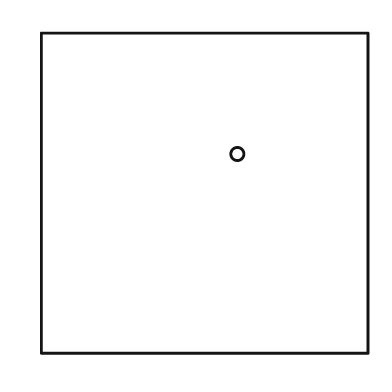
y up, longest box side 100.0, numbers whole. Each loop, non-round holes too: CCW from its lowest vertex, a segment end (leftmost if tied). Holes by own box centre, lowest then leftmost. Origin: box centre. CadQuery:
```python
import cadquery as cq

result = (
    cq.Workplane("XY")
    .moveTo(-50.0, -49.0)
    .lineTo(50.0, -49.0)
    .lineTo(50.0, 49.0)
    .lineTo(-50.0, 49.0)
    .close()
    .moveTo(10.0, 12.0)
    .circle(2.0)
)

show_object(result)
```